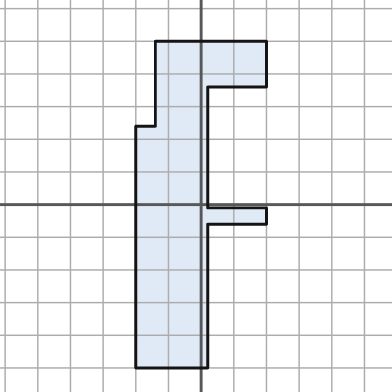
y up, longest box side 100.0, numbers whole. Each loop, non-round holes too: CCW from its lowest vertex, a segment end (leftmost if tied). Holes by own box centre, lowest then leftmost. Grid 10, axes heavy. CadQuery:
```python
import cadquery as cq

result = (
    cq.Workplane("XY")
    .moveTo(-20.0, -50.0)
    .lineTo(2.0, -50.0)
    .lineTo(2.0, -6.0)
    .lineTo(20.0, -6.0)
    .lineTo(20.0, -1.0)
    .lineTo(2.0, -1.0)
    .lineTo(2.0, 36.0)
    .lineTo(20.0, 36.0)
    .lineTo(20.0, 50.0)
    .lineTo(-14.0, 50.0)
    .lineTo(-14.0, 24.0)
    .lineTo(-20.0, 24.0)
    .close()
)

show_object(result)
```